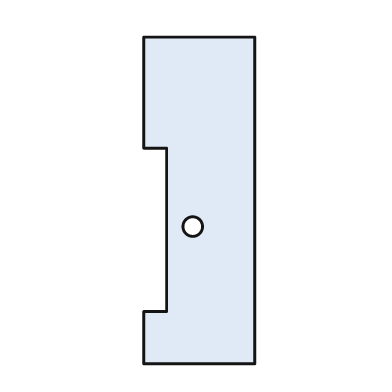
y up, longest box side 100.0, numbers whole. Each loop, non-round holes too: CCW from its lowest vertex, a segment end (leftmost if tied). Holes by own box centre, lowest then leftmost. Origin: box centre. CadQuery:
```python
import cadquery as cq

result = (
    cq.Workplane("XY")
    .moveTo(-17.0, -50.0)
    .lineTo(17.0, -50.0)
    .lineTo(17.0, 50.0)
    .lineTo(-17.0, 50.0)
    .lineTo(-17.0, 16.0)
    .lineTo(-10.0, 16.0)
    .lineTo(-10.0, -34.0)
    .lineTo(-17.0, -34.0)
    .close()
    .moveTo(-2.0, -8.0)
    .circle(3.0)
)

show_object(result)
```